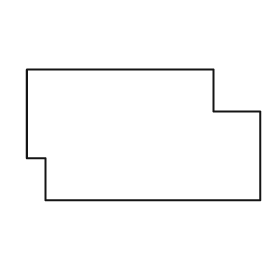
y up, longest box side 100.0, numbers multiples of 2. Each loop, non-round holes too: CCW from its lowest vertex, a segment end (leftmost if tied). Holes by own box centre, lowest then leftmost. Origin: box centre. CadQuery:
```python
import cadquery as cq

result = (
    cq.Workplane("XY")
    .moveTo(-42.0, -28.0)
    .lineTo(50.0, -28.0)
    .lineTo(50.0, 10.0)
    .lineTo(30.0, 10.0)
    .lineTo(30.0, 28.0)
    .lineTo(-50.0, 28.0)
    .lineTo(-50.0, -10.0)
    .lineTo(-42.0, -10.0)
    .close()
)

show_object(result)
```